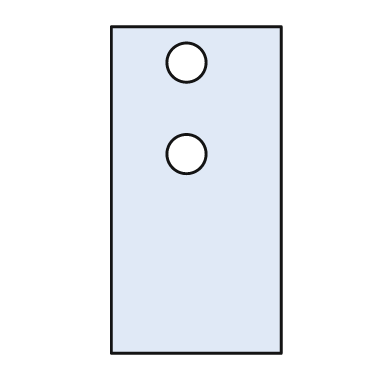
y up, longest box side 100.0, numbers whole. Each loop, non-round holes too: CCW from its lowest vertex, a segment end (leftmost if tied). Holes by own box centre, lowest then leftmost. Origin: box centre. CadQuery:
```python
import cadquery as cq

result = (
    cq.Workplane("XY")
    .moveTo(-26.0, -50.0)
    .lineTo(26.0, -50.0)
    .lineTo(26.0, 50.0)
    .lineTo(-26.0, 50.0)
    .close()
    .moveTo(-3.0, 11.0)
    .circle(6.0)
    .moveTo(-3.0, 39.0)
    .circle(6.0)
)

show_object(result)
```